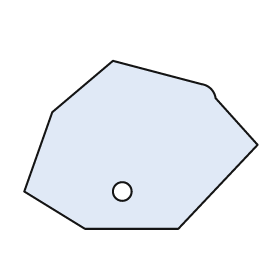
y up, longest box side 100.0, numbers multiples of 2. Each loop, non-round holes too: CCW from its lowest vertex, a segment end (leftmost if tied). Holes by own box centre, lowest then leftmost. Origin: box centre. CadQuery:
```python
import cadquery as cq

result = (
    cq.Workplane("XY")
    .moveTo(-24.0, -36.0)
    .lineTo(16.0, -36.0)
    .lineTo(50.0, 0.0)
    .lineTo(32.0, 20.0)
    .threePointArc((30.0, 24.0), (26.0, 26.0))
    .lineTo(-12.0, 36.0)
    .lineTo(-38.0, 14.0)
    .lineTo(-50.0, -20.0)
    .close()
    .moveTo(-8.0, -20.0)
    .circle(4.0)
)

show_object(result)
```